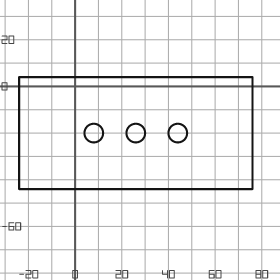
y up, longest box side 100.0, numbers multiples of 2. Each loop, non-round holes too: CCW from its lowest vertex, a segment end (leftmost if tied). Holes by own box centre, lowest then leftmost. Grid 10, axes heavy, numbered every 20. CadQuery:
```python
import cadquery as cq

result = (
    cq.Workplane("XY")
    .moveTo(-24.0, -44.0)
    .lineTo(76.0, -44.0)
    .lineTo(76.0, 4.0)
    .lineTo(-24.0, 4.0)
    .close()
    .moveTo(8.0, -20.0)
    .circle(4.0)
    .moveTo(26.0, -20.0)
    .circle(4.0)
    .moveTo(44.0, -20.0)
    .circle(4.0)
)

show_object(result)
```